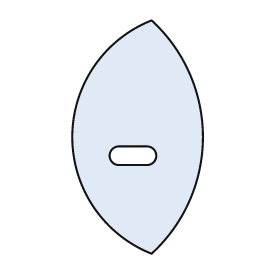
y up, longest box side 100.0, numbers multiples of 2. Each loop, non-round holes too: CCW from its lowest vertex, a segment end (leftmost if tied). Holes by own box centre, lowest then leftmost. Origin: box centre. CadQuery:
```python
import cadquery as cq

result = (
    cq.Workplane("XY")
    .moveTo(6.0, -50.0)
    .threePointArc((28.0, 0.0), (6.0, 50.0))
    .threePointArc((-28.0, 0.0), (6.0, -50.0))
    .close()
    .moveTo(-8.0, -12.0)
    .lineTo(4.0, -12.0)
    .threePointArc((8.0, -8.0), (4.0, -4.0))
    .lineTo(-8.0, -4.0)
    .threePointArc((-12.0, -8.0), (-8.0, -12.0))
    .close()
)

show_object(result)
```